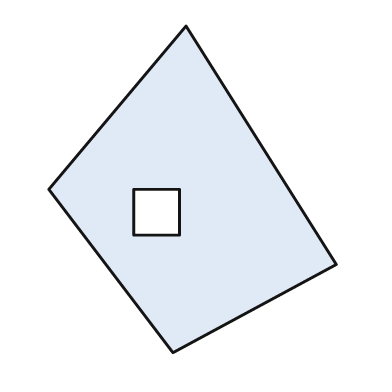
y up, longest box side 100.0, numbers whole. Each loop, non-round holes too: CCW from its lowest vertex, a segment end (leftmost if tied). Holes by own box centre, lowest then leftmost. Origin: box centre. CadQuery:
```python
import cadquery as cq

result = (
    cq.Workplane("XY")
    .moveTo(-6.0, -50.0)
    .lineTo(44.0, -23.0)
    .lineTo(-2.0, 50.0)
    .lineTo(-44.0, 0.0)
    .close()
    .moveTo(-18.0, -14.0)
    .lineTo(-4.0, -14.0)
    .lineTo(-4.0, 0.0)
    .lineTo(-18.0, 0.0)
    .close()
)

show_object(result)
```